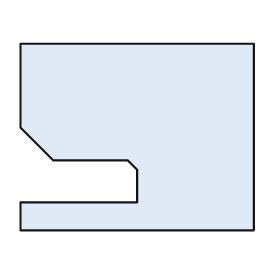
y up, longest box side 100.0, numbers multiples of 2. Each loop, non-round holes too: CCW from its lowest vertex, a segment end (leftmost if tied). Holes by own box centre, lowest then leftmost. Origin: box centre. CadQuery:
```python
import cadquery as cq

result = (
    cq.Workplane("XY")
    .moveTo(-50.0, -40.0)
    .lineTo(50.0, -40.0)
    .lineTo(50.0, 40.0)
    .lineTo(-50.0, 40.0)
    .lineTo(-50.0, 4.0)
    .lineTo(-36.0, -10.0)
    .lineTo(-4.0, -10.0)
    .lineTo(0.0, -14.0)
    .lineTo(0.0, -28.0)
    .lineTo(-50.0, -28.0)
    .close()
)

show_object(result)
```